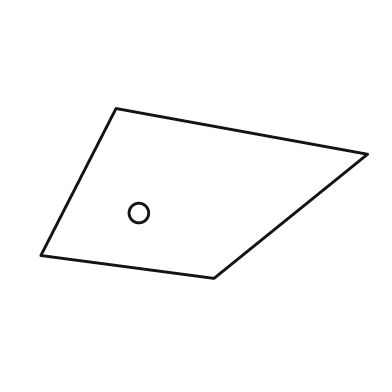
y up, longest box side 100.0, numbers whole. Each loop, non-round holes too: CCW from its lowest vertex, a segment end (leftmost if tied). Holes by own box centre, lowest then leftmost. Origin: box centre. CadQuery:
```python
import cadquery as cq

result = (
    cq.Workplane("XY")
    .moveTo(3.0, -26.0)
    .lineTo(50.0, 12.0)
    .lineTo(-27.0, 26.0)
    .lineTo(-50.0, -19.0)
    .close()
    .moveTo(-20.0, -6.0)
    .circle(3.0)
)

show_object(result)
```